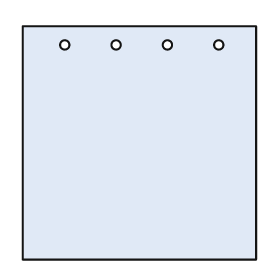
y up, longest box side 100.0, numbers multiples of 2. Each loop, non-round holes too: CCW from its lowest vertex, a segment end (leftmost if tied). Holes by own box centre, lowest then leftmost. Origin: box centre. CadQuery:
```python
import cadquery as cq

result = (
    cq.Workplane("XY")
    .moveTo(-50.0, -50.0)
    .lineTo(50.0, -50.0)
    .lineTo(50.0, 50.0)
    .lineTo(-50.0, 50.0)
    .close()
    .moveTo(-32.0, 42.0)
    .circle(2.0)
    .moveTo(-10.0, 42.0)
    .circle(2.0)
    .moveTo(12.0, 42.0)
    .circle(2.0)
    .moveTo(34.0, 42.0)
    .circle(2.0)
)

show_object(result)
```